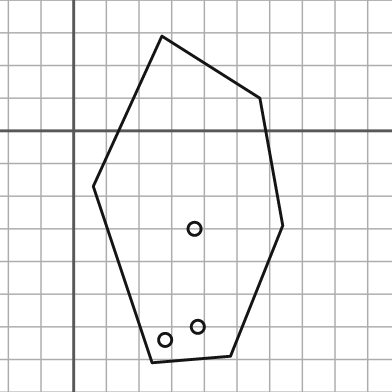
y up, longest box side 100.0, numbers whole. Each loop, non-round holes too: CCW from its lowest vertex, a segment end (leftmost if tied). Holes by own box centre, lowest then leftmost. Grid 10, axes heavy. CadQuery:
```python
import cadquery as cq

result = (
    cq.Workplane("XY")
    .moveTo(24.0, -71.0)
    .lineTo(48.0, -69.0)
    .lineTo(64.0, -29.0)
    .lineTo(57.0, 10.0)
    .lineTo(27.0, 29.0)
    .lineTo(6.0, -17.0)
    .close()
    .moveTo(28.0, -64.0)
    .circle(2.0)
    .moveTo(38.0, -60.0)
    .circle(2.0)
    .moveTo(37.0, -30.0)
    .circle(2.0)
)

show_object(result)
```